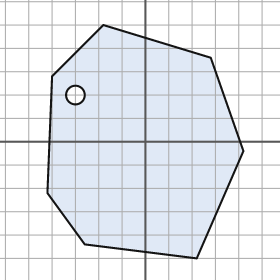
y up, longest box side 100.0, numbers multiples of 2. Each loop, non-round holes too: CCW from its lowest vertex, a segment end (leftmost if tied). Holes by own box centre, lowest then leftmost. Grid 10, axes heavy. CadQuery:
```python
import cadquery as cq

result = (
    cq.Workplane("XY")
    .moveTo(22.0, -50.0)
    .lineTo(42.0, -4.0)
    .lineTo(28.0, 36.0)
    .lineTo(-18.0, 50.0)
    .lineTo(-40.0, 28.0)
    .lineTo(-42.0, -22.0)
    .lineTo(-26.0, -44.0)
    .close()
    .moveTo(-30.0, 20.0)
    .circle(4.0)
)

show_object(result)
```